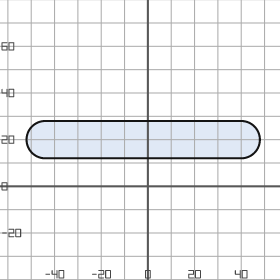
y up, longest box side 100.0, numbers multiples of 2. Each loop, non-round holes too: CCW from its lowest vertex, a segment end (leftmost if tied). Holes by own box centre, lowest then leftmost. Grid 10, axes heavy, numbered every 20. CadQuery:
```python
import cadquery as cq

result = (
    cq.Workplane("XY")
    .moveTo(-44.0, 12.0)
    .lineTo(40.0, 12.0)
    .threePointArc((48.0, 20.0), (40.0, 28.0))
    .lineTo(-44.0, 28.0)
    .threePointArc((-52.0, 20.0), (-44.0, 12.0))
    .close()
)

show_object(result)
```